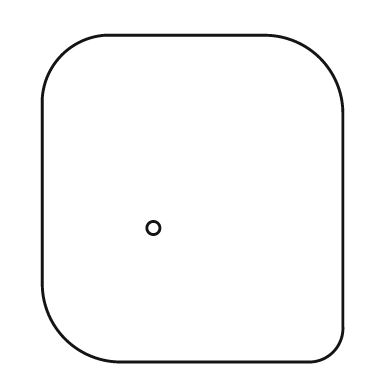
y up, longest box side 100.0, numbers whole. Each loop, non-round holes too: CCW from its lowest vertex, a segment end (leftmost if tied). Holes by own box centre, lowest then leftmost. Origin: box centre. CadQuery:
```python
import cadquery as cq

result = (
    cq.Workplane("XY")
    .moveTo(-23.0, -50.0)
    .lineTo(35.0, -50.0)
    .threePointArc((43.0, -47.0), (46.0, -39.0))
    .lineTo(46.0, 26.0)
    .threePointArc((39.0, 43.0), (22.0, 50.0))
    .lineTo(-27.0, 50.0)
    .threePointArc((-40.0, 44.0), (-46.0, 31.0))
    .lineTo(-46.0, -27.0)
    .threePointArc((-39.0, -43.0), (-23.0, -50.0))
    .close()
    .moveTo(-12.0, -9.0)
    .circle(2.0)
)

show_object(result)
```